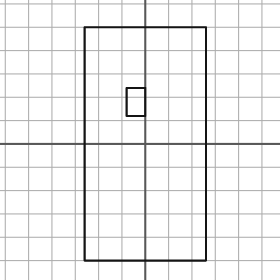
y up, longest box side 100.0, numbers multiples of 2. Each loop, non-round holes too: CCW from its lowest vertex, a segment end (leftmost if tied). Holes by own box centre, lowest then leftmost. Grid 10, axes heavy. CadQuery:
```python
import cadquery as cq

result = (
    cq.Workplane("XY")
    .moveTo(-26.0, -50.0)
    .lineTo(26.0, -50.0)
    .lineTo(26.0, 50.0)
    .lineTo(-26.0, 50.0)
    .close()
    .moveTo(-8.0, 12.0)
    .lineTo(0.0, 12.0)
    .lineTo(0.0, 24.0)
    .lineTo(-8.0, 24.0)
    .close()
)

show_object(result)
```